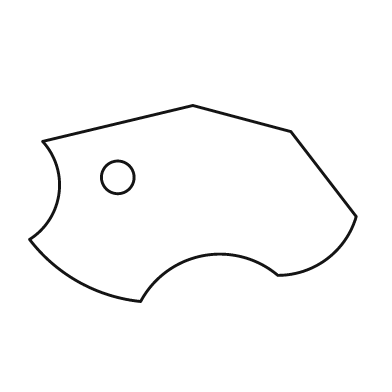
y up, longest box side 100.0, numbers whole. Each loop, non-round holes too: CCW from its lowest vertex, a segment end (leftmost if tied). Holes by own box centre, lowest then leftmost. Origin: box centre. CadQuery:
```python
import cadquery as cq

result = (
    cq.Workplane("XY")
    .moveTo(-16.0, -30.0)
    .threePointArc((3.0, -16.0), (26.0, -22.0))
    .threePointArc((41.0, -17.0), (50.0, -4.0))
    .lineTo(30.0, 22.0)
    .lineTo(0.0, 30.0)
    .lineTo(-46.0, 19.0)
    .threePointArc((-41.0, 3.0), (-50.0, -11.0))
    .threePointArc((-35.0, -24.0), (-16.0, -30.0))
    .close()
    .moveTo(-23.0, 8.0)
    .circle(5.0)
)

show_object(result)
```